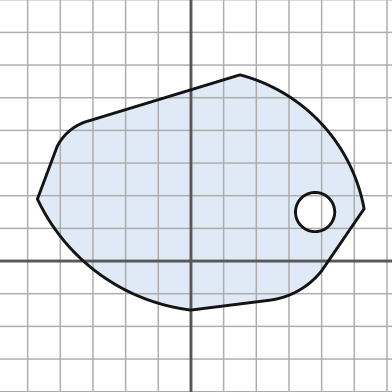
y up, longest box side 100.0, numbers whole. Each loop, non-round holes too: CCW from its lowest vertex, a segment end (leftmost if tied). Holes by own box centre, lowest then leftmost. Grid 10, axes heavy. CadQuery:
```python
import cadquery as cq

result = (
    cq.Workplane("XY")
    .moveTo(0.0, -15.0)
    .lineTo(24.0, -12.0)
    .threePointArc((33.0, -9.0), (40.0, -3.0))
    .lineTo(53.0, 16.0)
    .threePointArc((40.0, 42.0), (15.0, 57.0))
    .lineTo(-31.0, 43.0)
    .threePointArc((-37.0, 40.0), (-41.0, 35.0))
    .lineTo(-47.0, 19.0)
    .threePointArc((-28.0, -4.0), (0.0, -15.0))
    .close()
    .moveTo(38.0, 15.0)
    .circle(6.0)
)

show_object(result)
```